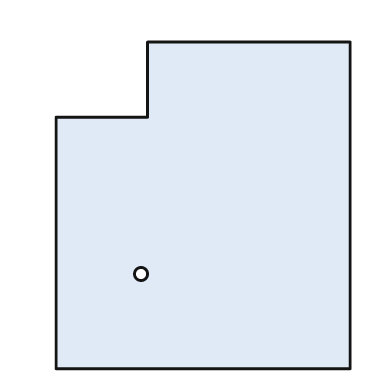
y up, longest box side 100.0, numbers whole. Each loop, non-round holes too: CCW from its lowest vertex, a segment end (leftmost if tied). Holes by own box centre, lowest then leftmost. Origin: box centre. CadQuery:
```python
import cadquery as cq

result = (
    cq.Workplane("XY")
    .moveTo(-45.0, -50.0)
    .lineTo(45.0, -50.0)
    .lineTo(45.0, 50.0)
    .lineTo(-17.0, 50.0)
    .lineTo(-17.0, 27.0)
    .lineTo(-45.0, 27.0)
    .close()
    .moveTo(-19.0, -21.0)
    .circle(2.0)
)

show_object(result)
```